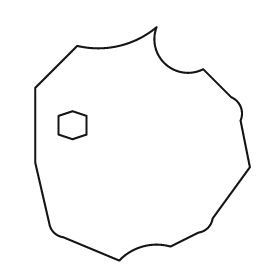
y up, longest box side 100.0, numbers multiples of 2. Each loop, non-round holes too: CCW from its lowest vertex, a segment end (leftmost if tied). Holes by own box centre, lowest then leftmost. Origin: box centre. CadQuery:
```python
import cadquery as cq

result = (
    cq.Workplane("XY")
    .moveTo(-10.0, -50.0)
    .threePointArc((0.0, -44.0), (12.0, -44.0))
    .lineTo(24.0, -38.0)
    .threePointArc((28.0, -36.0), (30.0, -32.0))
    .lineTo(46.0, -10.0)
    .lineTo(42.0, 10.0)
    .threePointArc((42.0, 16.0), (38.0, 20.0))
    .lineTo(26.0, 32.0)
    .threePointArc((10.0, 34.0), (6.0, 50.0))
    .threePointArc((-10.0, 42.0), (-28.0, 42.0))
    .lineTo(-46.0, 24.0)
    .lineTo(-46.0, -8.0)
    .lineTo(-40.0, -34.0)
    .threePointArc((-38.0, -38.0), (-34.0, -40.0))
    .close()
    .moveTo(-30.0, 2.0)
    .lineTo(-24.0, 4.0)
    .lineTo(-24.0, 12.0)
    .lineTo(-30.0, 14.0)
    .lineTo(-36.0, 12.0)
    .lineTo(-36.0, 4.0)
    .close()
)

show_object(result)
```